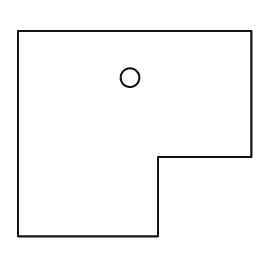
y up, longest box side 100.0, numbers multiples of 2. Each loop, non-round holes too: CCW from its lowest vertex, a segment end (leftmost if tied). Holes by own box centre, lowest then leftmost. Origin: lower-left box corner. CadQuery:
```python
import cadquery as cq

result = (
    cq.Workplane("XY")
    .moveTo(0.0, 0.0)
    .lineTo(60.0, 0.0)
    .lineTo(60.0, 34.0)
    .lineTo(100.0, 34.0)
    .lineTo(100.0, 88.0)
    .lineTo(0.0, 88.0)
    .close()
    .moveTo(48.0, 68.0)
    .circle(4.0)
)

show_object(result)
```